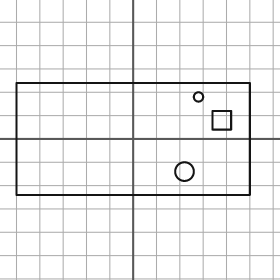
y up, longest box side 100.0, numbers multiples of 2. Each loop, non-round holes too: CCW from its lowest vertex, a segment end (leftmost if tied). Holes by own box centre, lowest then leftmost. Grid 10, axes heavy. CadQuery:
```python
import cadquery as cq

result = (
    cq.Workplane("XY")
    .moveTo(-50.0, -24.0)
    .lineTo(50.0, -24.0)
    .lineTo(50.0, 24.0)
    .lineTo(-50.0, 24.0)
    .close()
    .moveTo(22.0, -14.0)
    .circle(4.0)
    .moveTo(34.0, 4.0)
    .lineTo(42.0, 4.0)
    .lineTo(42.0, 12.0)
    .lineTo(34.0, 12.0)
    .close()
    .moveTo(28.0, 18.0)
    .circle(2.0)
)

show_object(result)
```